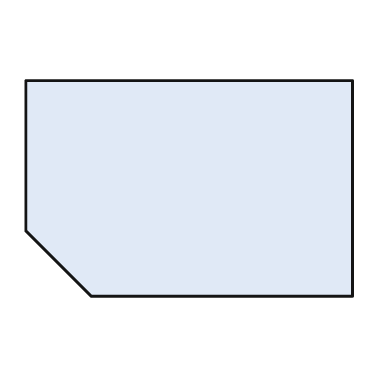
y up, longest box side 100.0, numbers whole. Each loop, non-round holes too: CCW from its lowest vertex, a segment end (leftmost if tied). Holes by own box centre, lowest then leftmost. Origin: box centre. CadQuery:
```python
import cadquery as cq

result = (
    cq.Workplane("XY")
    .moveTo(-30.0, -33.0)
    .lineTo(50.0, -33.0)
    .lineTo(50.0, 33.0)
    .lineTo(-50.0, 33.0)
    .lineTo(-50.0, -13.0)
    .close()
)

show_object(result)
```